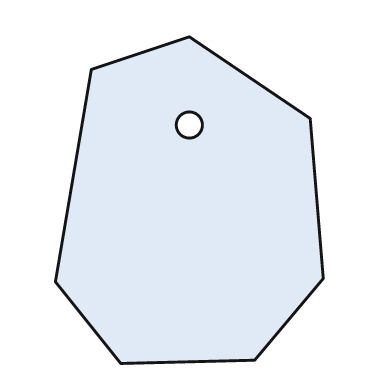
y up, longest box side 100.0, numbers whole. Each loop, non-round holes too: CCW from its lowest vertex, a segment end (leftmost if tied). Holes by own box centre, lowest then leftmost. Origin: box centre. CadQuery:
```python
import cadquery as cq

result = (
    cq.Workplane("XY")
    .moveTo(-21.0, -50.0)
    .lineTo(20.0, -49.0)
    .lineTo(41.0, -24.0)
    .lineTo(37.0, 25.0)
    .lineTo(0.0, 50.0)
    .lineTo(-30.0, 40.0)
    .lineTo(-41.0, -25.0)
    .close()
    .moveTo(0.0, 23.0)
    .circle(4.0)
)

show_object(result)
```